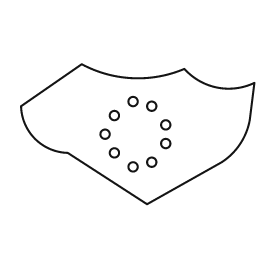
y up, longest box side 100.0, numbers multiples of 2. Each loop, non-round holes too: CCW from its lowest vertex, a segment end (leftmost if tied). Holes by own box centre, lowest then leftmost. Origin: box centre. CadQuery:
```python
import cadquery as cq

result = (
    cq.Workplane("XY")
    .moveTo(4.0, -30.0)
    .lineTo(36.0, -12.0)
    .threePointArc((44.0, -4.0), (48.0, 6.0))
    .lineTo(50.0, 22.0)
    .threePointArc((34.0, 20.0), (20.0, 28.0))
    .threePointArc((-2.0, 24.0), (-24.0, 30.0))
    .lineTo(-50.0, 12.0)
    .threePointArc((-44.0, -2.0), (-30.0, -8.0))
    .close()
    .moveTo(-2.0, -14.0)
    .circle(2.0)
    .moveTo(6.0, -12.0)
    .circle(2.0)
    .moveTo(-10.0, -8.0)
    .circle(2.0)
    .moveTo(12.0, -4.0)
    .circle(2.0)
    .moveTo(-14.0, 0.0)
    .circle(2.0)
    .moveTo(12.0, 4.0)
    .circle(2.0)
    .moveTo(-10.0, 8.0)
    .circle(2.0)
    .moveTo(6.0, 12.0)
    .circle(2.0)
    .moveTo(-2.0, 14.0)
    .circle(2.0)
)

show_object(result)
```